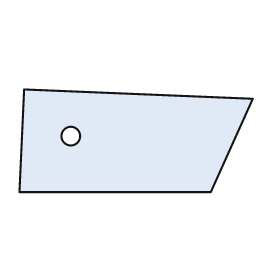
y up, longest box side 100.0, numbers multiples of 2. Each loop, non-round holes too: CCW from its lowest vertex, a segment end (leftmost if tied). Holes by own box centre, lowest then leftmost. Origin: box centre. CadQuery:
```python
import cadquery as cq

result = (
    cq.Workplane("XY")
    .moveTo(-50.0, -22.0)
    .lineTo(32.0, -22.0)
    .lineTo(50.0, 18.0)
    .lineTo(-48.0, 22.0)
    .close()
    .moveTo(-28.0, 2.0)
    .circle(4.0)
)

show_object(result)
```